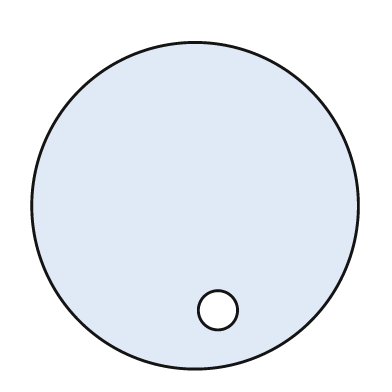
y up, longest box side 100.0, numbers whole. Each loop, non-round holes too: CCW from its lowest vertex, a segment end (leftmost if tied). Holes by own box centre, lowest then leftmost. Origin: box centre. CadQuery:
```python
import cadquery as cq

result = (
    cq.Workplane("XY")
    .moveTo(0.0, 0.0)
    .circle(50.0)
    .moveTo(7.0, -32.0)
    .circle(6.0)
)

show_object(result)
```